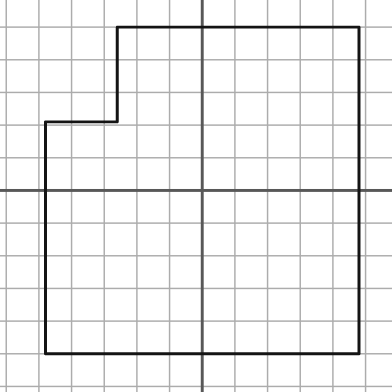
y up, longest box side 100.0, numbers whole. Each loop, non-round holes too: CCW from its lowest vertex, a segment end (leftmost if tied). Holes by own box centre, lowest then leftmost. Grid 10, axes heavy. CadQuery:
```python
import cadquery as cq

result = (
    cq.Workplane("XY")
    .moveTo(-48.0, -50.0)
    .lineTo(48.0, -50.0)
    .lineTo(48.0, 50.0)
    .lineTo(-26.0, 50.0)
    .lineTo(-26.0, 21.0)
    .lineTo(-48.0, 21.0)
    .close()
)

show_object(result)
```